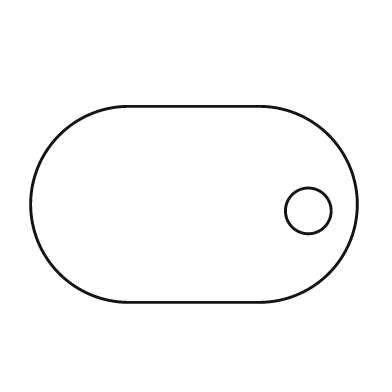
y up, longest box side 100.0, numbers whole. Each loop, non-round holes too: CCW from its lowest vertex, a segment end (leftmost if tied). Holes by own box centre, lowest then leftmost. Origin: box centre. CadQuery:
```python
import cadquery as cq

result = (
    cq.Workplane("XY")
    .moveTo(-20.0, -30.0)
    .lineTo(20.0, -30.0)
    .threePointArc((50.0, 0.0), (20.0, 30.0))
    .lineTo(-20.0, 30.0)
    .threePointArc((-50.0, 0.0), (-20.0, -30.0))
    .close()
    .moveTo(35.0, -2.0)
    .circle(7.0)
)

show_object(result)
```